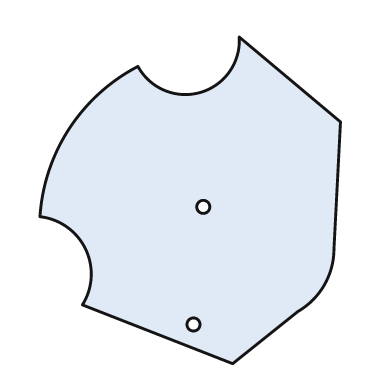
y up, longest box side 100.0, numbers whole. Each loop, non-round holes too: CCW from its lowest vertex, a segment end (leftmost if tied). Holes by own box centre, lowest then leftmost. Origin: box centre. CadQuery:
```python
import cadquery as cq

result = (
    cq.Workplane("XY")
    .moveTo(13.0, -50.0)
    .lineTo(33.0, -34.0)
    .threePointArc((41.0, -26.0), (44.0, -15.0))
    .lineTo(46.0, 24.0)
    .lineTo(15.0, 50.0)
    .threePointArc((3.0, 33.0), (-16.0, 41.0))
    .threePointArc((-37.0, 22.0), (-46.0, -5.0))
    .threePointArc((-32.0, -15.0), (-33.0, -32.0))
    .close()
    .moveTo(1.0, -38.0)
    .circle(2.0)
    .moveTo(4.0, -2.0)
    .circle(2.0)
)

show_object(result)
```